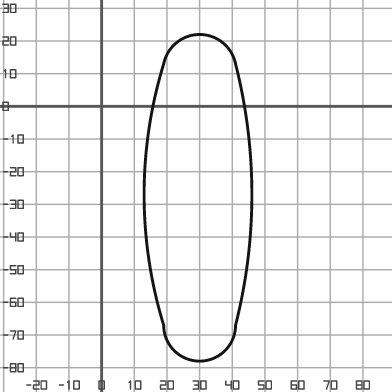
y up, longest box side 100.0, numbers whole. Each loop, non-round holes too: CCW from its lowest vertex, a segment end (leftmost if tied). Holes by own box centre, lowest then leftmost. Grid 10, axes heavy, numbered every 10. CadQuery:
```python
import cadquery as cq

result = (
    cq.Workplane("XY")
    .moveTo(19.0, -67.0)
    .threePointArc((30.0, -78.0), (41.0, -67.0))
    .threePointArc((46.0, -27.0), (41.0, 13.0))
    .threePointArc((30.0, 22.0), (19.0, 13.0))
    .threePointArc((13.0, -27.0), (19.0, -67.0))
    .close()
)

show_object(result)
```